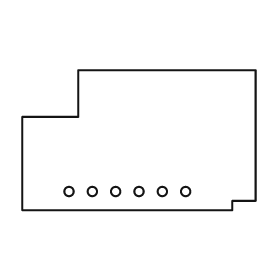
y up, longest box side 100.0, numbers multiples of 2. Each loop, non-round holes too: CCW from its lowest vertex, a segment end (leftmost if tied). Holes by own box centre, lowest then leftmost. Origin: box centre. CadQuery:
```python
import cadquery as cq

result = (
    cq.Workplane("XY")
    .moveTo(-50.0, -30.0)
    .lineTo(40.0, -30.0)
    .lineTo(40.0, -26.0)
    .lineTo(50.0, -26.0)
    .lineTo(50.0, 30.0)
    .lineTo(-26.0, 30.0)
    .lineTo(-26.0, 10.0)
    .lineTo(-50.0, 10.0)
    .close()
    .moveTo(-30.0, -22.0)
    .circle(2.0)
    .moveTo(-20.0, -22.0)
    .circle(2.0)
    .moveTo(-10.0, -22.0)
    .circle(2.0)
    .moveTo(0.0, -22.0)
    .circle(2.0)
    .moveTo(10.0, -22.0)
    .circle(2.0)
    .moveTo(20.0, -22.0)
    .circle(2.0)
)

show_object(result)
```